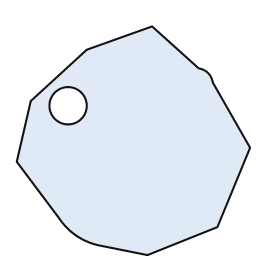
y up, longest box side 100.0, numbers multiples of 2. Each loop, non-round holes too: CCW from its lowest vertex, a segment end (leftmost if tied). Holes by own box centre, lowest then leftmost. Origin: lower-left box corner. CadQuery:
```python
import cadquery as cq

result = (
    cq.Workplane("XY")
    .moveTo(56.0, 0.0)
    .lineTo(86.0, 12.0)
    .lineTo(100.0, 46.0)
    .lineTo(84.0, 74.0)
    .threePointArc((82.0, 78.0), (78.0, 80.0))
    .lineTo(58.0, 98.0)
    .lineTo(30.0, 88.0)
    .lineTo(6.0, 66.0)
    .lineTo(0.0, 40.0)
    .lineTo(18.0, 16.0)
    .threePointArc((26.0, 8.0), (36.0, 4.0))
    .close()
    .moveTo(22.0, 64.0)
    .circle(8.0)
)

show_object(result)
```